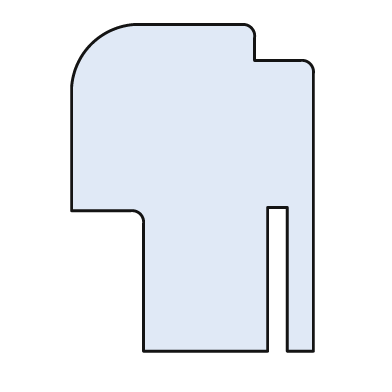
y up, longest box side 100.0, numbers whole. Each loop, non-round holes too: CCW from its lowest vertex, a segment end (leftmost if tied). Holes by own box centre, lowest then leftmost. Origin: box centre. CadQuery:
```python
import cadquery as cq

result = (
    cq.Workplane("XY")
    .moveTo(-15.0, -50.0)
    .lineTo(23.0, -50.0)
    .lineTo(23.0, -6.0)
    .lineTo(29.0, -6.0)
    .lineTo(29.0, -50.0)
    .lineTo(37.0, -50.0)
    .lineTo(37.0, 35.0)
    .threePointArc((36.0, 38.0), (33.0, 39.0))
    .lineTo(19.0, 39.0)
    .lineTo(19.0, 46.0)
    .threePointArc((18.0, 49.0), (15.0, 50.0))
    .lineTo(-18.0, 50.0)
    .threePointArc((-31.0, 44.0), (-37.0, 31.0))
    .lineTo(-37.0, -7.0)
    .lineTo(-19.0, -7.0)
    .threePointArc((-16.0, -8.0), (-15.0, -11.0))
    .close()
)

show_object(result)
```